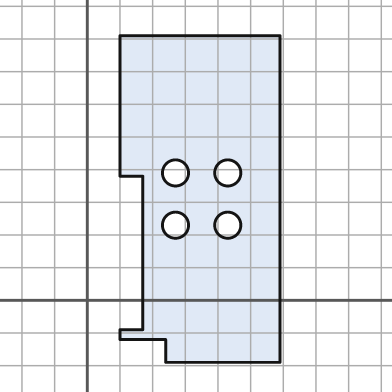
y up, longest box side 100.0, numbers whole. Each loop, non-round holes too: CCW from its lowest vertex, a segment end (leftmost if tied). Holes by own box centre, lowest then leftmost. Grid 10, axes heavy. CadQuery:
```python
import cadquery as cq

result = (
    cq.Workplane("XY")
    .moveTo(24.0, -19.0)
    .lineTo(59.0, -19.0)
    .lineTo(59.0, 81.0)
    .lineTo(10.0, 81.0)
    .lineTo(10.0, 38.0)
    .lineTo(17.0, 38.0)
    .lineTo(17.0, -9.0)
    .lineTo(10.0, -9.0)
    .lineTo(10.0, -12.0)
    .lineTo(24.0, -12.0)
    .close()
    .moveTo(27.0, 23.0)
    .circle(4.0)
    .moveTo(43.0, 23.0)
    .circle(4.0)
    .moveTo(27.0, 39.0)
    .circle(4.0)
    .moveTo(43.0, 39.0)
    .circle(4.0)
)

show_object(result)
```